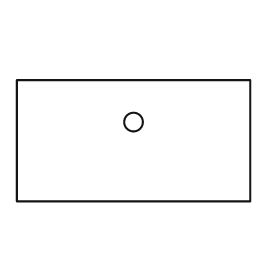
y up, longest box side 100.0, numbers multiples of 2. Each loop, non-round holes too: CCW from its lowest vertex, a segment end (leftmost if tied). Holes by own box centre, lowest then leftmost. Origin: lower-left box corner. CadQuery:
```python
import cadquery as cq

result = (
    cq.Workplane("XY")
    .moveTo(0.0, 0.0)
    .lineTo(100.0, 0.0)
    .lineTo(100.0, 52.0)
    .lineTo(0.0, 52.0)
    .close()
    .moveTo(50.0, 34.0)
    .circle(4.0)
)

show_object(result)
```